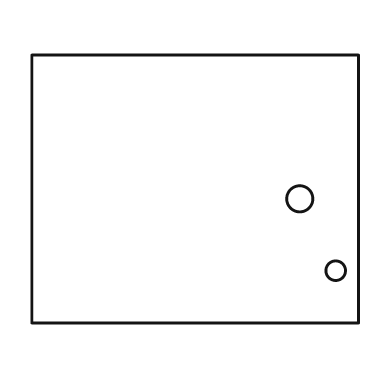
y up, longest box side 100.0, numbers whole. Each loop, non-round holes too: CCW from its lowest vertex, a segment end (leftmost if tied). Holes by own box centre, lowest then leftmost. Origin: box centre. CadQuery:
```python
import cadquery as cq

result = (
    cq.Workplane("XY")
    .moveTo(-50.0, -41.0)
    .lineTo(50.0, -41.0)
    .lineTo(50.0, 41.0)
    .lineTo(-50.0, 41.0)
    .close()
    .moveTo(43.0, -25.0)
    .circle(3.0)
    .moveTo(32.0, -3.0)
    .circle(4.0)
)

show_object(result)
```